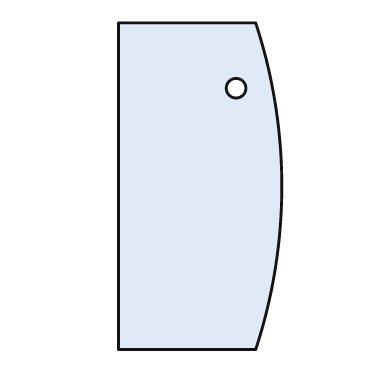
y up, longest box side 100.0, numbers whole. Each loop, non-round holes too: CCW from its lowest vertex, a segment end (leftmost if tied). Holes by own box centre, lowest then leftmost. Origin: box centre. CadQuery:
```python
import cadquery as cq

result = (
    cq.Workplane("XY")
    .moveTo(-25.0, -50.0)
    .lineTo(17.0, -50.0)
    .threePointArc((25.0, 0.0), (17.0, 50.0))
    .lineTo(-25.0, 50.0)
    .close()
    .moveTo(11.0, 30.0)
    .circle(3.0)
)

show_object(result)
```